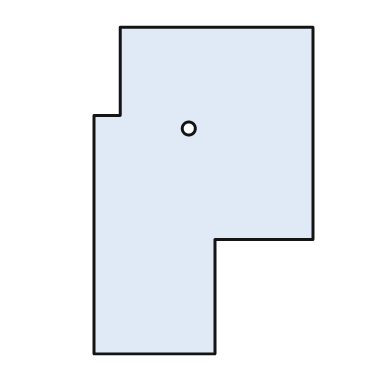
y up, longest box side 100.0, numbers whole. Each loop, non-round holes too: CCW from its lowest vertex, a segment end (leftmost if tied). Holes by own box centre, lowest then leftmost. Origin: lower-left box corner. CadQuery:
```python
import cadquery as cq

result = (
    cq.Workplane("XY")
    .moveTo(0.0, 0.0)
    .lineTo(37.0, 0.0)
    .lineTo(37.0, 35.0)
    .lineTo(67.0, 35.0)
    .lineTo(67.0, 100.0)
    .lineTo(8.0, 100.0)
    .lineTo(8.0, 73.0)
    .lineTo(0.0, 73.0)
    .close()
    .moveTo(29.0, 69.0)
    .circle(2.0)
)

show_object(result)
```